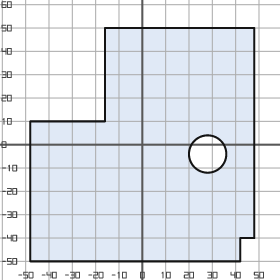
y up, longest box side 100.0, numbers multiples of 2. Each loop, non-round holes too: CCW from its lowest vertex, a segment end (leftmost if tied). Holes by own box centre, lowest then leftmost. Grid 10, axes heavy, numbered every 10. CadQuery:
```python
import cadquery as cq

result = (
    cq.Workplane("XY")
    .moveTo(-48.0, -50.0)
    .lineTo(42.0, -50.0)
    .lineTo(42.0, -40.0)
    .lineTo(48.0, -40.0)
    .lineTo(48.0, 50.0)
    .lineTo(-16.0, 50.0)
    .lineTo(-16.0, 10.0)
    .lineTo(-48.0, 10.0)
    .close()
    .moveTo(28.0, -4.0)
    .circle(8.0)
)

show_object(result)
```